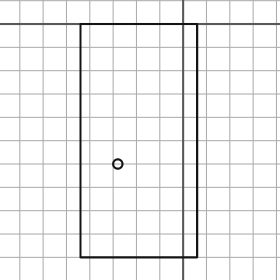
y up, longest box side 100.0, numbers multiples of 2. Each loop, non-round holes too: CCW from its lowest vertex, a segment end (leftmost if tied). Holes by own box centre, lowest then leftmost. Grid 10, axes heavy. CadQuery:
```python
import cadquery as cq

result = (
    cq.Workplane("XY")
    .moveTo(-44.0, -100.0)
    .lineTo(6.0, -100.0)
    .lineTo(6.0, 0.0)
    .lineTo(-44.0, 0.0)
    .close()
    .moveTo(-28.0, -60.0)
    .circle(2.0)
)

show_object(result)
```